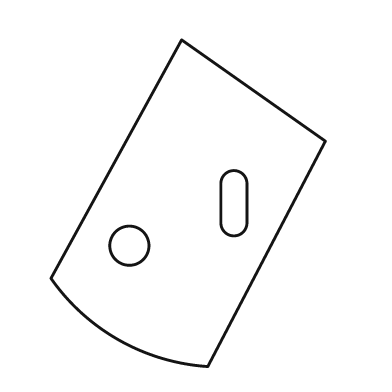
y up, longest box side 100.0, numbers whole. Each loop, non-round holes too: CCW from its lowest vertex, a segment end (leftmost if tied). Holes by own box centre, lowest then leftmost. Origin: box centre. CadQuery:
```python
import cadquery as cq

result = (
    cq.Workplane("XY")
    .moveTo(6.0, -50.0)
    .lineTo(42.0, 19.0)
    .lineTo(-2.0, 50.0)
    .lineTo(-42.0, -23.0)
    .threePointArc((-21.0, -42.0), (6.0, -50.0))
    .close()
    .moveTo(-18.0, -13.0)
    .circle(6.0)
    .moveTo(10.0, -6.0)
    .threePointArc((14.0, -10.0), (18.0, -6.0))
    .lineTo(18.0, 6.0)
    .threePointArc((14.0, 10.0), (10.0, 6.0))
    .close()
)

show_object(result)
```